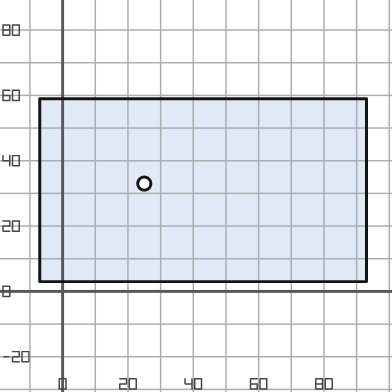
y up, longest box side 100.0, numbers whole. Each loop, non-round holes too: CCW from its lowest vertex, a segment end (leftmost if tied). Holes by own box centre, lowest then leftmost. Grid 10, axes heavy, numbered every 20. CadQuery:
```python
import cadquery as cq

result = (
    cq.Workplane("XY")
    .moveTo(-7.0, 3.0)
    .lineTo(93.0, 3.0)
    .lineTo(93.0, 59.0)
    .lineTo(-7.0, 59.0)
    .close()
    .moveTo(25.0, 33.0)
    .circle(2.0)
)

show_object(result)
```